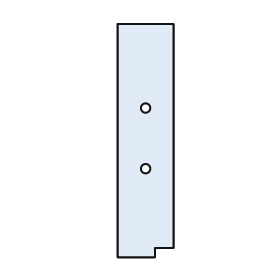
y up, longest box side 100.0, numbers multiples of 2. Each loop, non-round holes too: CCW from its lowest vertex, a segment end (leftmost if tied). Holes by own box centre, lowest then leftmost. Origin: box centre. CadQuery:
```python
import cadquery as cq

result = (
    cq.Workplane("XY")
    .moveTo(-12.0, -50.0)
    .lineTo(4.0, -50.0)
    .lineTo(4.0, -46.0)
    .lineTo(12.0, -46.0)
    .lineTo(12.0, 50.0)
    .lineTo(-12.0, 50.0)
    .close()
    .moveTo(0.0, -12.0)
    .circle(2.0)
    .moveTo(0.0, 14.0)
    .circle(2.0)
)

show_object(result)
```